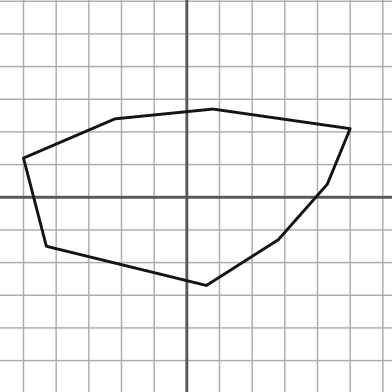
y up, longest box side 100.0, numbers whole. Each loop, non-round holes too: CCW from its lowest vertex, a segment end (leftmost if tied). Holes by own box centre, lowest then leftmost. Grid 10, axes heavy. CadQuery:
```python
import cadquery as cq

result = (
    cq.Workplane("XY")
    .moveTo(6.0, -27.0)
    .lineTo(28.0, -13.0)
    .lineTo(43.0, 4.0)
    .lineTo(50.0, 21.0)
    .lineTo(8.0, 27.0)
    .lineTo(-22.0, 24.0)
    .lineTo(-50.0, 12.0)
    .lineTo(-43.0, -15.0)
    .close()
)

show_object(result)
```